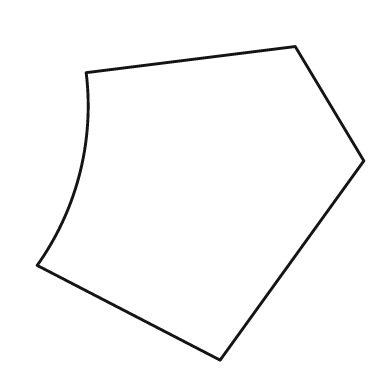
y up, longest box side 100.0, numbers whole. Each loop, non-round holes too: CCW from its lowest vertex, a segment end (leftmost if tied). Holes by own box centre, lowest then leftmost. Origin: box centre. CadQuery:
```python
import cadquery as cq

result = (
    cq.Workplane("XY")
    .moveTo(6.0, -48.0)
    .lineTo(50.0, 13.0)
    .lineTo(29.0, 48.0)
    .lineTo(-35.0, 40.0)
    .threePointArc((-37.0, 9.0), (-50.0, -19.0))
    .close()
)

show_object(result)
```